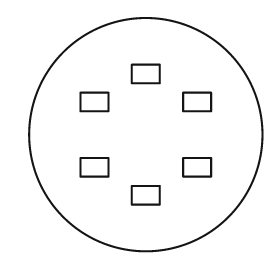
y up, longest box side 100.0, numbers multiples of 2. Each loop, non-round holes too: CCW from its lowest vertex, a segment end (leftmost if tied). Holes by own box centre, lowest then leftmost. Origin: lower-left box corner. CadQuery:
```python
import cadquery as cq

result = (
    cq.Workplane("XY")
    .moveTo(50.0, 50.0)
    .circle(50.0)
    .moveTo(44.0, 20.0)
    .lineTo(56.0, 20.0)
    .lineTo(56.0, 28.0)
    .lineTo(44.0, 28.0)
    .close()
    .moveTo(22.0, 32.0)
    .lineTo(34.0, 32.0)
    .lineTo(34.0, 40.0)
    .lineTo(22.0, 40.0)
    .close()
    .moveTo(66.0, 32.0)
    .lineTo(78.0, 32.0)
    .lineTo(78.0, 40.0)
    .lineTo(66.0, 40.0)
    .close()
    .moveTo(22.0, 60.0)
    .lineTo(34.0, 60.0)
    .lineTo(34.0, 68.0)
    .lineTo(22.0, 68.0)
    .close()
    .moveTo(66.0, 60.0)
    .lineTo(78.0, 60.0)
    .lineTo(78.0, 68.0)
    .lineTo(66.0, 68.0)
    .close()
    .moveTo(44.0, 72.0)
    .lineTo(56.0, 72.0)
    .lineTo(56.0, 80.0)
    .lineTo(44.0, 80.0)
    .close()
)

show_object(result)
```